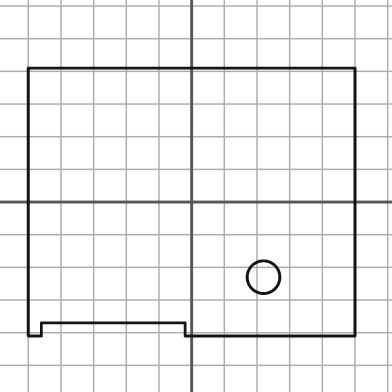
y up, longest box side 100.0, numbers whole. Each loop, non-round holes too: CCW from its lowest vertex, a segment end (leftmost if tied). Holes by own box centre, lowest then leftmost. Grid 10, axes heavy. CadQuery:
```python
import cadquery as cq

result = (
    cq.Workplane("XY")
    .moveTo(-50.0, -41.0)
    .lineTo(-46.0, -41.0)
    .lineTo(-46.0, -37.0)
    .lineTo(-2.0, -37.0)
    .lineTo(-2.0, -41.0)
    .lineTo(50.0, -41.0)
    .lineTo(50.0, 41.0)
    .lineTo(-50.0, 41.0)
    .close()
    .moveTo(22.0, -23.0)
    .circle(5.0)
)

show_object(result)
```